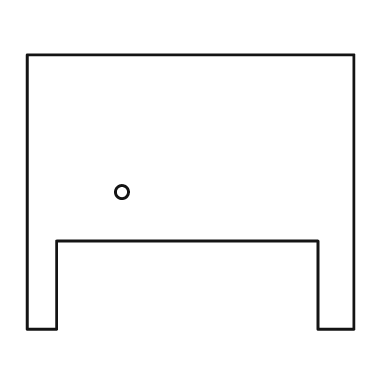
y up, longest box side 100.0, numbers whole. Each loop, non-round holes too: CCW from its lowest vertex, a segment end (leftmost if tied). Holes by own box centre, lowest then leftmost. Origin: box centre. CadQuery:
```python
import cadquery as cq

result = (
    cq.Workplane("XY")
    .moveTo(-50.0, -42.0)
    .lineTo(-41.0, -42.0)
    .lineTo(-41.0, -15.0)
    .lineTo(39.0, -15.0)
    .lineTo(39.0, -42.0)
    .lineTo(50.0, -42.0)
    .lineTo(50.0, 42.0)
    .lineTo(-50.0, 42.0)
    .close()
    .moveTo(-21.0, 0.0)
    .circle(2.0)
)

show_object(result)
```